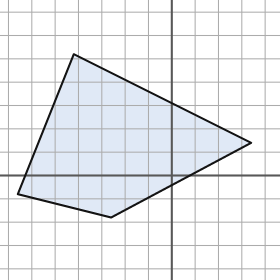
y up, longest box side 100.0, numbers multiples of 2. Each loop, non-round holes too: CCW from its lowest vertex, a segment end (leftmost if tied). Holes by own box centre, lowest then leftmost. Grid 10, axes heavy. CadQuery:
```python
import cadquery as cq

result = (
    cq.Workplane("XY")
    .moveTo(-26.0, -18.0)
    .lineTo(34.0, 14.0)
    .lineTo(-42.0, 52.0)
    .lineTo(-66.0, -8.0)
    .close()
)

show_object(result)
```